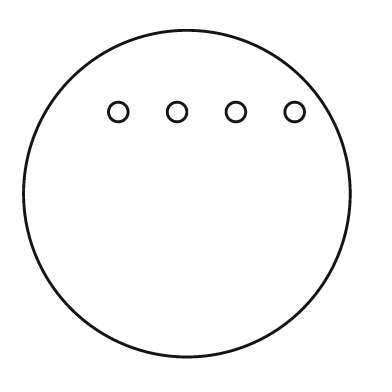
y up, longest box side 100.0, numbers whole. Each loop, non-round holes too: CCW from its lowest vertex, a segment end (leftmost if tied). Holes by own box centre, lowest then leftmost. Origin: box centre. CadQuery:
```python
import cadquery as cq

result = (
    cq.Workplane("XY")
    .moveTo(0.0, 0.0)
    .circle(50.0)
    .moveTo(-21.0, 25.0)
    .circle(3.0)
    .moveTo(-3.0, 25.0)
    .circle(3.0)
    .moveTo(15.0, 25.0)
    .circle(3.0)
    .moveTo(33.0, 25.0)
    .circle(3.0)
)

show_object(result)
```